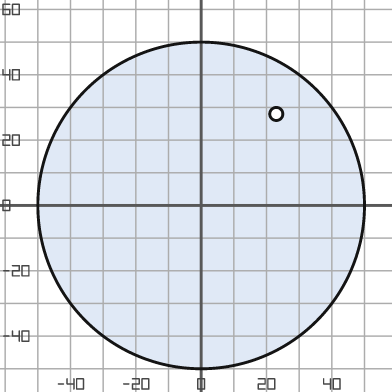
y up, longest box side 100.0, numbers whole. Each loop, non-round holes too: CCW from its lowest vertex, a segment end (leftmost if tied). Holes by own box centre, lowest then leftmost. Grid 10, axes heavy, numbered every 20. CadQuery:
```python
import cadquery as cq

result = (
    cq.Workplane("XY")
    .moveTo(0.0, 0.0)
    .circle(50.0)
    .moveTo(23.0, 28.0)
    .circle(2.0)
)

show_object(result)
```